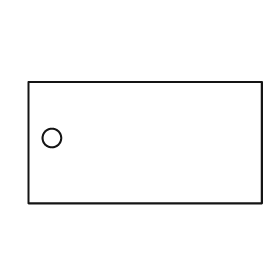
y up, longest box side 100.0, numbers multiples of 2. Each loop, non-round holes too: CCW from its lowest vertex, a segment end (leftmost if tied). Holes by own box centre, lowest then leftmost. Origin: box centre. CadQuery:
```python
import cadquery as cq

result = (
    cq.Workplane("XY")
    .moveTo(-50.0, -26.0)
    .lineTo(50.0, -26.0)
    .lineTo(50.0, 26.0)
    .lineTo(-50.0, 26.0)
    .close()
    .moveTo(-40.0, 2.0)
    .circle(4.0)
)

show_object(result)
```